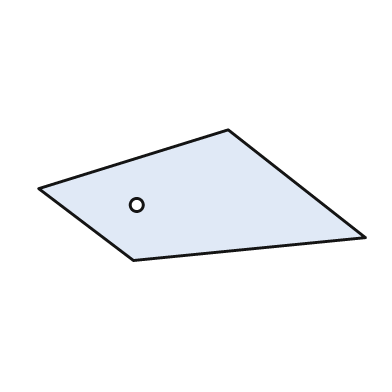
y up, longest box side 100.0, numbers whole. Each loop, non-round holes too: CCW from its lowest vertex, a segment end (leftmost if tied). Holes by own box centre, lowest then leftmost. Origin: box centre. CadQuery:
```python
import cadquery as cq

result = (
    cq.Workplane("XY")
    .moveTo(-21.0, -20.0)
    .lineTo(50.0, -13.0)
    .lineTo(8.0, 20.0)
    .lineTo(-50.0, 2.0)
    .close()
    .moveTo(-20.0, -3.0)
    .circle(2.0)
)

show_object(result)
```